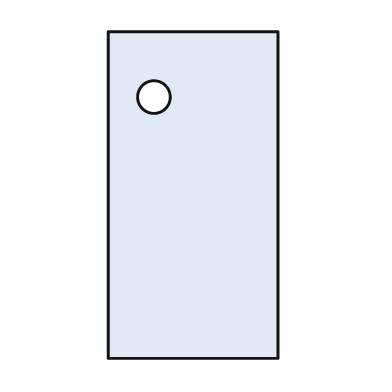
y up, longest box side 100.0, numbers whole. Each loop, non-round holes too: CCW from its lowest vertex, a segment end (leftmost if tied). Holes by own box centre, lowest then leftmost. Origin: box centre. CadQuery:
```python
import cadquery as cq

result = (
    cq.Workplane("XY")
    .moveTo(-26.0, -50.0)
    .lineTo(26.0, -50.0)
    .lineTo(26.0, 50.0)
    .lineTo(-26.0, 50.0)
    .close()
    .moveTo(-12.0, 30.0)
    .circle(5.0)
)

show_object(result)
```